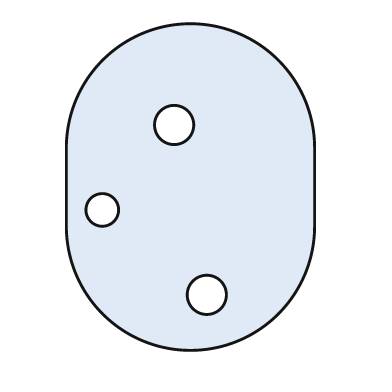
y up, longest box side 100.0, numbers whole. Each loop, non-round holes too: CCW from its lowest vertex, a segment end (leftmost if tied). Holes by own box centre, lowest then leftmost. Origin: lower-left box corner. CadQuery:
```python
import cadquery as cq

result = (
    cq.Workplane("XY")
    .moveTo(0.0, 38.0)
    .threePointArc((38.0, 0.0), (76.0, 38.0))
    .lineTo(76.0, 62.0)
    .threePointArc((38.0, 100.0), (0.0, 62.0))
    .close()
    .moveTo(43.0, 17.0)
    .circle(6.0)
    .moveTo(11.0, 43.0)
    .circle(5.0)
    .moveTo(33.0, 69.0)
    .circle(6.0)
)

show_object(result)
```